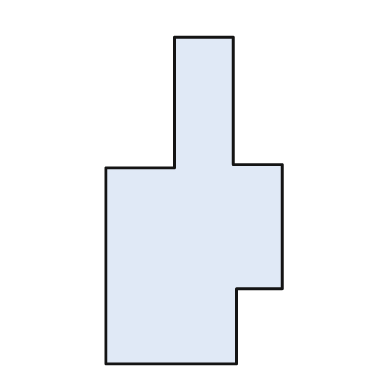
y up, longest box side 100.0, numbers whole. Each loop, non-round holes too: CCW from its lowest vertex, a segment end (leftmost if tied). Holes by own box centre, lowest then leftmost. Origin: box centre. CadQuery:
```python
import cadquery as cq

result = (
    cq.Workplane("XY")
    .moveTo(-27.0, -50.0)
    .lineTo(13.0, -50.0)
    .lineTo(13.0, -27.0)
    .lineTo(27.0, -27.0)
    .lineTo(27.0, 11.0)
    .lineTo(12.0, 11.0)
    .lineTo(12.0, 50.0)
    .lineTo(-6.0, 50.0)
    .lineTo(-6.0, 10.0)
    .lineTo(-27.0, 10.0)
    .close()
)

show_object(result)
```